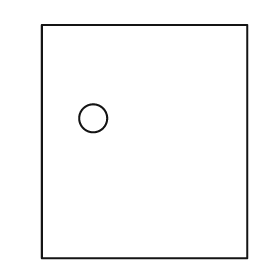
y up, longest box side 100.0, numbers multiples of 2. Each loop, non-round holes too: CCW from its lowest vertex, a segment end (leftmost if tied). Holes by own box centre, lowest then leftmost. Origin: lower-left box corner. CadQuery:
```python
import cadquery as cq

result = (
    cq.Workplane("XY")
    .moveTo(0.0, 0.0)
    .lineTo(88.0, 0.0)
    .lineTo(88.0, 100.0)
    .lineTo(0.0, 100.0)
    .close()
    .moveTo(22.0, 60.0)
    .circle(6.0)
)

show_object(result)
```